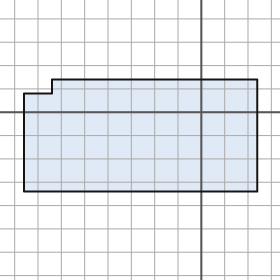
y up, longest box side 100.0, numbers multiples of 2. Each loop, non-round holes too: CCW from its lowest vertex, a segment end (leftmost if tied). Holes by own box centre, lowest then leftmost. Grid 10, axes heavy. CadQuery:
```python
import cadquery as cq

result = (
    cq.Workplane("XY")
    .moveTo(-76.0, -34.0)
    .lineTo(24.0, -34.0)
    .lineTo(24.0, 14.0)
    .lineTo(-64.0, 14.0)
    .lineTo(-64.0, 8.0)
    .lineTo(-76.0, 8.0)
    .close()
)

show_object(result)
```